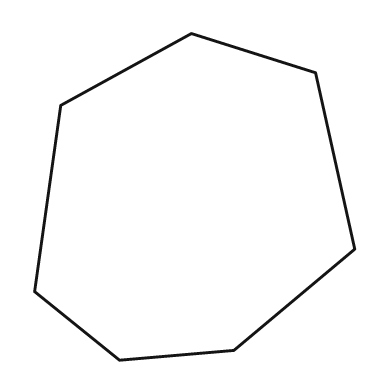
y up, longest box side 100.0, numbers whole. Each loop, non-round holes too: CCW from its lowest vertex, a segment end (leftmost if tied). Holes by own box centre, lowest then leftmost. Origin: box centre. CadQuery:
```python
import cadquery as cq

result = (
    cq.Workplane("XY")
    .moveTo(-23.0, -50.0)
    .lineTo(12.0, -47.0)
    .lineTo(49.0, -16.0)
    .lineTo(37.0, 38.0)
    .lineTo(-1.0, 50.0)
    .lineTo(-41.0, 28.0)
    .lineTo(-49.0, -29.0)
    .close()
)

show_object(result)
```